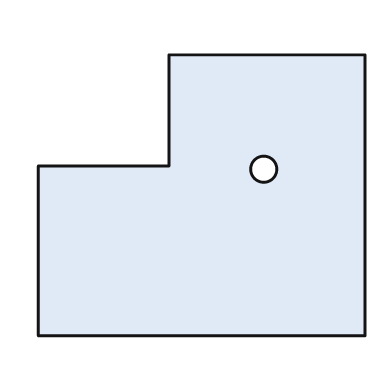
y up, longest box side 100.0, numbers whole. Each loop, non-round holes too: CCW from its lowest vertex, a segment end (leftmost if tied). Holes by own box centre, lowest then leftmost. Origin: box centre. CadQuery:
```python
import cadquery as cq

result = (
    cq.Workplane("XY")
    .moveTo(-50.0, -43.0)
    .lineTo(50.0, -43.0)
    .lineTo(50.0, 43.0)
    .lineTo(-10.0, 43.0)
    .lineTo(-10.0, 9.0)
    .lineTo(-50.0, 9.0)
    .close()
    .moveTo(19.0, 8.0)
    .circle(4.0)
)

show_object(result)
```